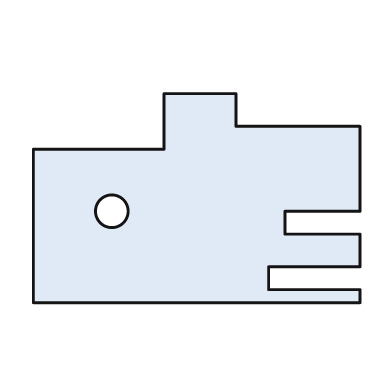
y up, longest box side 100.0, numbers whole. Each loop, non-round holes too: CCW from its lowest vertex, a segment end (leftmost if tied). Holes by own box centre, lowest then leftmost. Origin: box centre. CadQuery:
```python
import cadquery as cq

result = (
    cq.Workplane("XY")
    .moveTo(-50.0, -32.0)
    .lineTo(50.0, -32.0)
    .lineTo(50.0, -28.0)
    .lineTo(22.0, -28.0)
    .lineTo(22.0, -21.0)
    .lineTo(50.0, -21.0)
    .lineTo(50.0, -11.0)
    .lineTo(27.0, -11.0)
    .lineTo(27.0, -4.0)
    .lineTo(50.0, -4.0)
    .lineTo(50.0, 22.0)
    .lineTo(12.0, 22.0)
    .lineTo(12.0, 32.0)
    .lineTo(-10.0, 32.0)
    .lineTo(-10.0, 15.0)
    .lineTo(-50.0, 15.0)
    .close()
    .moveTo(-26.0, -4.0)
    .circle(5.0)
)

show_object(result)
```